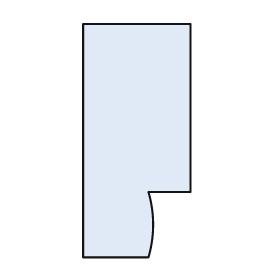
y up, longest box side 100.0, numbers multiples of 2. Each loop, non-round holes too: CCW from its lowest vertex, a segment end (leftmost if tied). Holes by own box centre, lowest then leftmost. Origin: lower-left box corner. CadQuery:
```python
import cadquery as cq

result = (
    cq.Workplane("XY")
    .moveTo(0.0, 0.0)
    .lineTo(28.0, 0.0)
    .threePointArc((30.0, 14.0), (28.0, 28.0))
    .lineTo(46.0, 28.0)
    .lineTo(46.0, 100.0)
    .lineTo(0.0, 100.0)
    .close()
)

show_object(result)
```